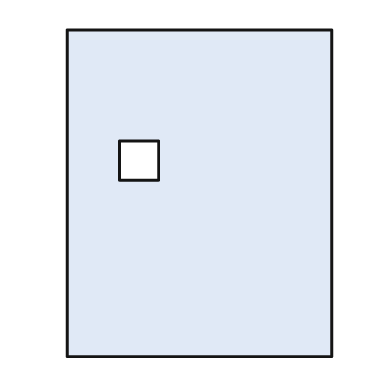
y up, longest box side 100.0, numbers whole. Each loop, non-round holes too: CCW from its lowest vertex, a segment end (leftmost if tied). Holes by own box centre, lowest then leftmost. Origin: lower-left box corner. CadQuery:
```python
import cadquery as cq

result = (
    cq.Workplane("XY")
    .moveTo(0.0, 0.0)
    .lineTo(81.0, 0.0)
    .lineTo(81.0, 100.0)
    .lineTo(0.0, 100.0)
    .close()
    .moveTo(16.0, 54.0)
    .lineTo(28.0, 54.0)
    .lineTo(28.0, 66.0)
    .lineTo(16.0, 66.0)
    .close()
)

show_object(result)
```